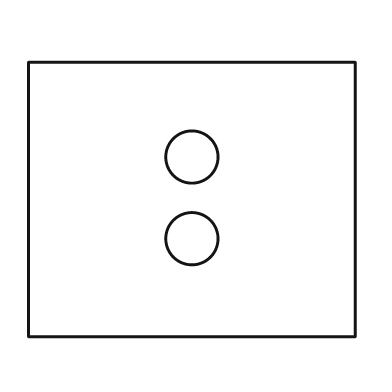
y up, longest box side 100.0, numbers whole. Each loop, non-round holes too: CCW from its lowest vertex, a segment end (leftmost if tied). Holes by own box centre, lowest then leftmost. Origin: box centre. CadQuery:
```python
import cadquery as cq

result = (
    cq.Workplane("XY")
    .moveTo(-50.0, -42.0)
    .lineTo(50.0, -42.0)
    .lineTo(50.0, 42.0)
    .lineTo(-50.0, 42.0)
    .close()
    .moveTo(0.0, -12.0)
    .circle(8.0)
    .moveTo(0.0, 13.0)
    .circle(8.0)
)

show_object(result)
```